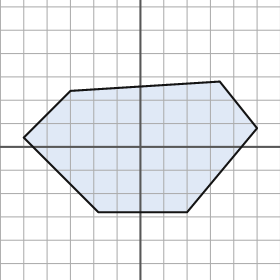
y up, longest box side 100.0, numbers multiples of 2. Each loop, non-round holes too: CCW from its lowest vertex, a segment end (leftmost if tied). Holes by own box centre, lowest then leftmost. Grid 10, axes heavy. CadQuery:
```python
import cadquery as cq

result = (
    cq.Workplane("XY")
    .moveTo(-18.0, -28.0)
    .lineTo(20.0, -28.0)
    .lineTo(50.0, 8.0)
    .lineTo(34.0, 28.0)
    .lineTo(-30.0, 24.0)
    .lineTo(-50.0, 4.0)
    .close()
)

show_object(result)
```